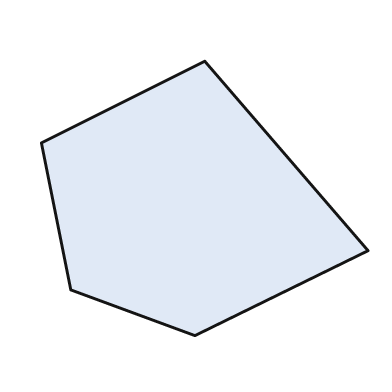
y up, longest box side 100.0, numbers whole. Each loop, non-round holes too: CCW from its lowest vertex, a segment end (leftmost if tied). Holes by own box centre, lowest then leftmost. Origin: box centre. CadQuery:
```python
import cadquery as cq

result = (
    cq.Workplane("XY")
    .moveTo(-3.0, -42.0)
    .lineTo(50.0, -16.0)
    .lineTo(0.0, 42.0)
    .lineTo(-50.0, 17.0)
    .lineTo(-41.0, -28.0)
    .close()
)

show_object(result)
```